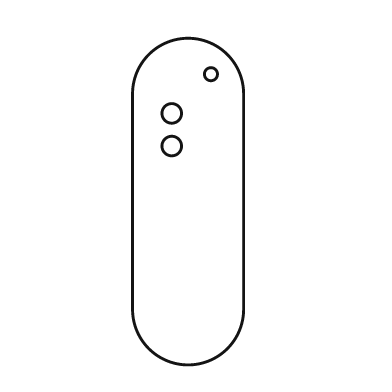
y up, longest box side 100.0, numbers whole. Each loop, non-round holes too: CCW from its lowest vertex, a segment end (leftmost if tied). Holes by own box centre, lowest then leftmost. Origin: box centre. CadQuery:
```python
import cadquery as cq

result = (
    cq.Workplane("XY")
    .moveTo(-17.0, -33.0)
    .threePointArc((0.0, -50.0), (17.0, -33.0))
    .lineTo(17.0, 33.0)
    .threePointArc((0.0, 50.0), (-17.0, 33.0))
    .close()
    .moveTo(-5.0, 17.0)
    .circle(3.0)
    .moveTo(-5.0, 27.0)
    .circle(3.0)
    .moveTo(7.0, 39.0)
    .circle(2.0)
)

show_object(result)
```